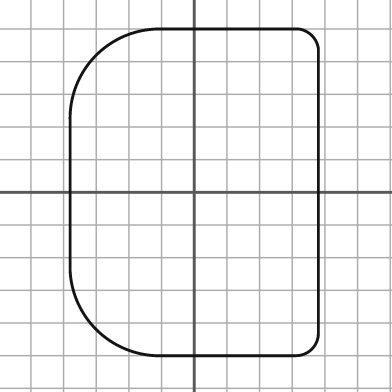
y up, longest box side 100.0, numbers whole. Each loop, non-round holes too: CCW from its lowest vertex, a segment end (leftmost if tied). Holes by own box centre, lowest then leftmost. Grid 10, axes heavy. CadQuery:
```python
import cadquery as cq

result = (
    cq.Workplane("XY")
    .moveTo(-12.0, -50.0)
    .lineTo(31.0, -50.0)
    .threePointArc((36.0, -48.0), (38.0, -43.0))
    .lineTo(38.0, 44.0)
    .threePointArc((36.0, 48.0), (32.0, 50.0))
    .lineTo(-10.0, 50.0)
    .threePointArc((-30.0, 42.0), (-38.0, 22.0))
    .lineTo(-38.0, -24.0)
    .threePointArc((-30.0, -42.0), (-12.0, -50.0))
    .close()
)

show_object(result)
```